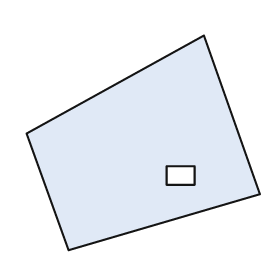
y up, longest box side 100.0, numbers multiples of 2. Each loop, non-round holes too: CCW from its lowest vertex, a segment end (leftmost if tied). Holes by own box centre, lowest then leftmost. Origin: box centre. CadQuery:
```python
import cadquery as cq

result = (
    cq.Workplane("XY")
    .moveTo(-32.0, -46.0)
    .lineTo(50.0, -22.0)
    .lineTo(26.0, 46.0)
    .lineTo(-50.0, 4.0)
    .close()
    .moveTo(10.0, -18.0)
    .lineTo(22.0, -18.0)
    .lineTo(22.0, -10.0)
    .lineTo(10.0, -10.0)
    .close()
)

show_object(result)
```